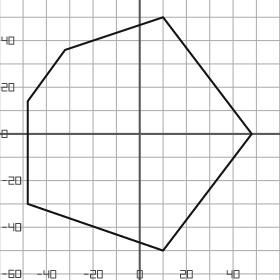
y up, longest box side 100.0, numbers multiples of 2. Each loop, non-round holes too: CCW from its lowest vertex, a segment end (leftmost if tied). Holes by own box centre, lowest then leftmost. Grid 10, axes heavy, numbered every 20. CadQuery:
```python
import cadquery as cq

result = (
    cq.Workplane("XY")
    .moveTo(10.0, -50.0)
    .lineTo(48.0, 0.0)
    .lineTo(10.0, 50.0)
    .lineTo(-32.0, 36.0)
    .lineTo(-48.0, 14.0)
    .lineTo(-48.0, -30.0)
    .close()
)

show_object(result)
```